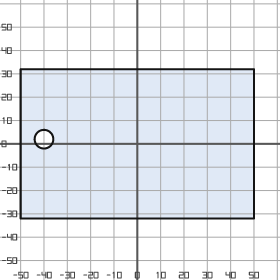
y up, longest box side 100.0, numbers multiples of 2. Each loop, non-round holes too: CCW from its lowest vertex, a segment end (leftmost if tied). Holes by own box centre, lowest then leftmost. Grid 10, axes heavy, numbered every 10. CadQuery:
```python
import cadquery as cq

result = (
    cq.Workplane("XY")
    .moveTo(-50.0, -32.0)
    .lineTo(50.0, -32.0)
    .lineTo(50.0, 32.0)
    .lineTo(-50.0, 32.0)
    .close()
    .moveTo(-40.0, 2.0)
    .circle(4.0)
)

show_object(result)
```